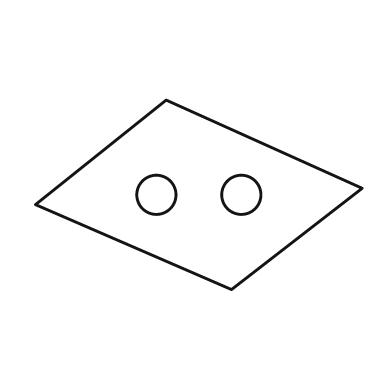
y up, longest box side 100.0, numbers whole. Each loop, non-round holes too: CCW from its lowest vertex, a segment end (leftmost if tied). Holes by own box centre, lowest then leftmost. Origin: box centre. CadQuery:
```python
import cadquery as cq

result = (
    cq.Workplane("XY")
    .moveTo(10.0, -29.0)
    .lineTo(50.0, 2.0)
    .lineTo(-10.0, 29.0)
    .lineTo(-50.0, -3.0)
    .close()
    .moveTo(-13.0, 0.0)
    .circle(6.0)
    .moveTo(13.0, 0.0)
    .circle(6.0)
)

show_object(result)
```